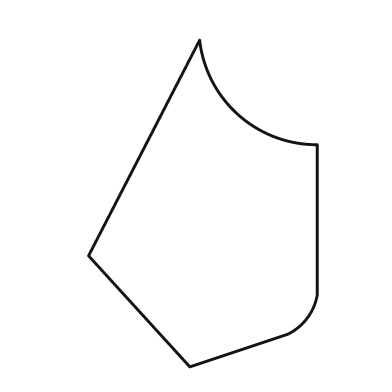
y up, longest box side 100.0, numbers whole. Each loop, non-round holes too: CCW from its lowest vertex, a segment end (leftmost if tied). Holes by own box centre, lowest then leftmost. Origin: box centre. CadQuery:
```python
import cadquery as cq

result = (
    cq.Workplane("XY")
    .moveTo(-4.0, -50.0)
    .lineTo(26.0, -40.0)
    .threePointArc((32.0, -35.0), (35.0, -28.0))
    .lineTo(35.0, 18.0)
    .threePointArc((11.0, 27.0), (-1.0, 50.0))
    .lineTo(-35.0, -16.0)
    .close()
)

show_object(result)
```